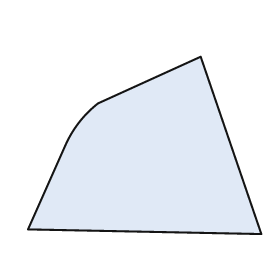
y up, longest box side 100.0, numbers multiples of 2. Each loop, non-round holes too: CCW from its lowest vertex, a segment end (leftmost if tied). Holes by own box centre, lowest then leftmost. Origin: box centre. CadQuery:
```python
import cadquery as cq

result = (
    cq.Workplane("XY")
    .moveTo(50.0, -38.0)
    .lineTo(24.0, 38.0)
    .lineTo(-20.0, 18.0)
    .threePointArc((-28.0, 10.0), (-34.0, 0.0))
    .lineTo(-50.0, -36.0)
    .close()
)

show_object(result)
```